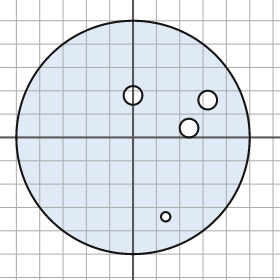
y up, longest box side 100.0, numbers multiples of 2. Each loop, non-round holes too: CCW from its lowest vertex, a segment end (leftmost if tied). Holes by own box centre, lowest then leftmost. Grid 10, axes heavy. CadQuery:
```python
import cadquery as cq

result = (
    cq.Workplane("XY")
    .moveTo(0.0, 0.0)
    .circle(50.0)
    .moveTo(14.0, -34.0)
    .circle(2.0)
    .moveTo(24.0, 4.0)
    .circle(4.0)
    .moveTo(32.0, 16.0)
    .circle(4.0)
    .moveTo(0.0, 18.0)
    .circle(4.0)
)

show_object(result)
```